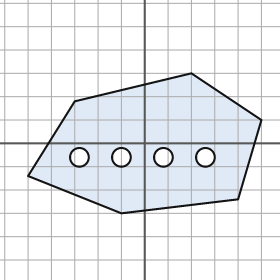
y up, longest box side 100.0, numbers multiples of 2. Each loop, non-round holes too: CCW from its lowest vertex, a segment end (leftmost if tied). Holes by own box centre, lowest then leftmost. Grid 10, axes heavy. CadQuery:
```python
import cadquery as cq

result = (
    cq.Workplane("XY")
    .moveTo(-10.0, -30.0)
    .lineTo(40.0, -24.0)
    .lineTo(50.0, 10.0)
    .lineTo(20.0, 30.0)
    .lineTo(-30.0, 18.0)
    .lineTo(-50.0, -14.0)
    .close()
    .moveTo(-28.0, -6.0)
    .circle(4.0)
    .moveTo(-10.0, -6.0)
    .circle(4.0)
    .moveTo(8.0, -6.0)
    .circle(4.0)
    .moveTo(26.0, -6.0)
    .circle(4.0)
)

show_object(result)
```